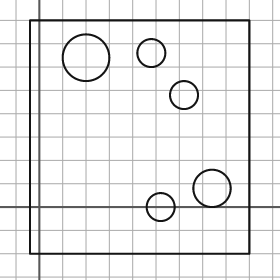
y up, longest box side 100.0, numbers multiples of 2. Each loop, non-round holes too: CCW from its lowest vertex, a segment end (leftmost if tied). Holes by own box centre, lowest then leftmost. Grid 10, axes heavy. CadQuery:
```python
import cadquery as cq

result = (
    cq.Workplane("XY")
    .moveTo(-4.0, -20.0)
    .lineTo(90.0, -20.0)
    .lineTo(90.0, 80.0)
    .lineTo(-4.0, 80.0)
    .close()
    .moveTo(52.0, 0.0)
    .circle(6.0)
    .moveTo(74.0, 8.0)
    .circle(8.0)
    .moveTo(62.0, 48.0)
    .circle(6.0)
    .moveTo(20.0, 64.0)
    .circle(10.0)
    .moveTo(48.0, 66.0)
    .circle(6.0)
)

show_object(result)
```